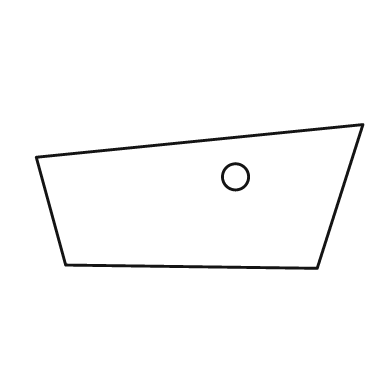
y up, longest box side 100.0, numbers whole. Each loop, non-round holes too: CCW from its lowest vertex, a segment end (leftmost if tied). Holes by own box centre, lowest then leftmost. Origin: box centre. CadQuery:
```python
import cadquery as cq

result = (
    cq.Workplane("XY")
    .moveTo(36.0, -22.0)
    .lineTo(50.0, 22.0)
    .lineTo(-50.0, 12.0)
    .lineTo(-41.0, -21.0)
    .close()
    .moveTo(11.0, 6.0)
    .circle(4.0)
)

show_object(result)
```